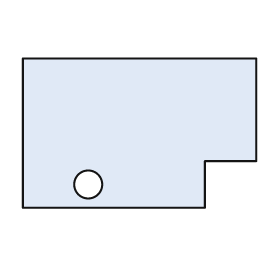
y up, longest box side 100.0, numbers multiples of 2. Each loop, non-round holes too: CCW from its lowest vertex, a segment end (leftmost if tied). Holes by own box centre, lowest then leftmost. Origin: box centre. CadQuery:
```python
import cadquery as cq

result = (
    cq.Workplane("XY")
    .moveTo(-50.0, -32.0)
    .lineTo(28.0, -32.0)
    .lineTo(28.0, -12.0)
    .lineTo(50.0, -12.0)
    .lineTo(50.0, 32.0)
    .lineTo(-50.0, 32.0)
    .close()
    .moveTo(-22.0, -22.0)
    .circle(6.0)
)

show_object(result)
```